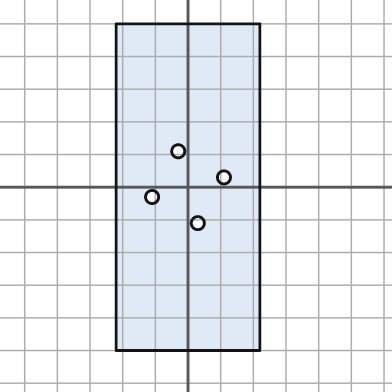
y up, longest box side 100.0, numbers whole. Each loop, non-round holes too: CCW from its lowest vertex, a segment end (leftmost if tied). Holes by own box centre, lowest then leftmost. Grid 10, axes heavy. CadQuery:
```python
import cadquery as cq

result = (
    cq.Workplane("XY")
    .moveTo(-22.0, -50.0)
    .lineTo(22.0, -50.0)
    .lineTo(22.0, 50.0)
    .lineTo(-22.0, 50.0)
    .close()
    .moveTo(3.0, -11.0)
    .circle(2.0)
    .moveTo(-11.0, -3.0)
    .circle(2.0)
    .moveTo(11.0, 3.0)
    .circle(2.0)
    .moveTo(-3.0, 11.0)
    .circle(2.0)
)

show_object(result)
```